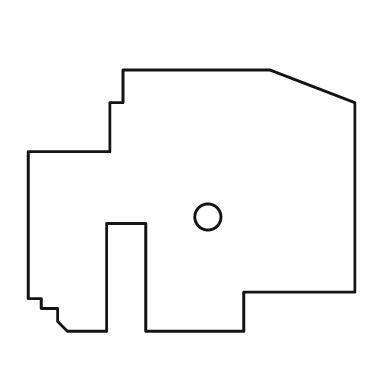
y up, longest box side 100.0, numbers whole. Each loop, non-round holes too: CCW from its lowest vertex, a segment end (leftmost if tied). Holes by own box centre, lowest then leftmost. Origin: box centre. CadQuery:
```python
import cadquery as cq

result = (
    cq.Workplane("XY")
    .moveTo(-38.0, -40.0)
    .lineTo(-26.0, -40.0)
    .lineTo(-26.0, -7.0)
    .lineTo(-14.0, -7.0)
    .lineTo(-14.0, -40.0)
    .lineTo(16.0, -40.0)
    .lineTo(16.0, -28.0)
    .lineTo(50.0, -28.0)
    .lineTo(50.0, 30.0)
    .lineTo(24.0, 40.0)
    .lineTo(-21.0, 40.0)
    .lineTo(-21.0, 30.0)
    .lineTo(-25.0, 30.0)
    .lineTo(-25.0, 15.0)
    .lineTo(-50.0, 15.0)
    .lineTo(-50.0, -30.0)
    .lineTo(-46.0, -30.0)
    .lineTo(-46.0, -33.0)
    .lineTo(-41.0, -33.0)
    .lineTo(-41.0, -37.0)
    .close()
    .moveTo(5.0, -5.0)
    .circle(4.0)
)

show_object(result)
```